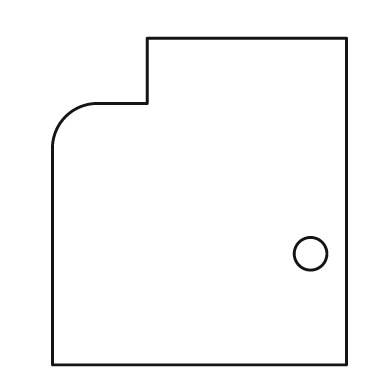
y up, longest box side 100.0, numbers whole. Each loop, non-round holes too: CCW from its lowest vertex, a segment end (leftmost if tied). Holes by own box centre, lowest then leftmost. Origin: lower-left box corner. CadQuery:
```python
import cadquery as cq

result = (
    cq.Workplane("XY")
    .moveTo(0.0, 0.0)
    .lineTo(90.0, 0.0)
    .lineTo(90.0, 100.0)
    .lineTo(29.0, 100.0)
    .lineTo(29.0, 80.0)
    .lineTo(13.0, 80.0)
    .threePointArc((4.0, 76.0), (0.0, 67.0))
    .close()
    .moveTo(79.0, 34.0)
    .circle(5.0)
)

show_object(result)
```